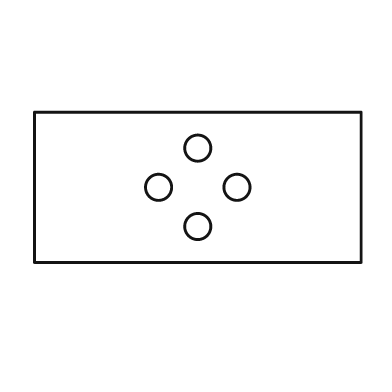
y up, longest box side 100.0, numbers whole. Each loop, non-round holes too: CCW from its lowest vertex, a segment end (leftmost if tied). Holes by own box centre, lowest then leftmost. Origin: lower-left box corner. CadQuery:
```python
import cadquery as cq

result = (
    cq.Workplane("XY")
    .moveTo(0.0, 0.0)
    .lineTo(100.0, 0.0)
    .lineTo(100.0, 46.0)
    .lineTo(0.0, 46.0)
    .close()
    .moveTo(50.0, 11.0)
    .circle(4.0)
    .moveTo(38.0, 23.0)
    .circle(4.0)
    .moveTo(62.0, 23.0)
    .circle(4.0)
    .moveTo(50.0, 35.0)
    .circle(4.0)
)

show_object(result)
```